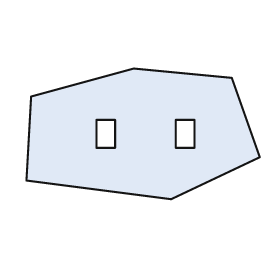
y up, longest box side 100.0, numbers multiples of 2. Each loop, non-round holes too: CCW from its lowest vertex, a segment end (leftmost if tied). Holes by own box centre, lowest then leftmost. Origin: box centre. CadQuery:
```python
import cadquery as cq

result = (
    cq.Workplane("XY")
    .moveTo(12.0, -28.0)
    .lineTo(50.0, -10.0)
    .lineTo(38.0, 24.0)
    .lineTo(-4.0, 28.0)
    .lineTo(-48.0, 16.0)
    .lineTo(-50.0, -20.0)
    .close()
    .moveTo(-20.0, -6.0)
    .lineTo(-12.0, -6.0)
    .lineTo(-12.0, 6.0)
    .lineTo(-20.0, 6.0)
    .close()
    .moveTo(14.0, -6.0)
    .lineTo(22.0, -6.0)
    .lineTo(22.0, 6.0)
    .lineTo(14.0, 6.0)
    .close()
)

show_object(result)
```